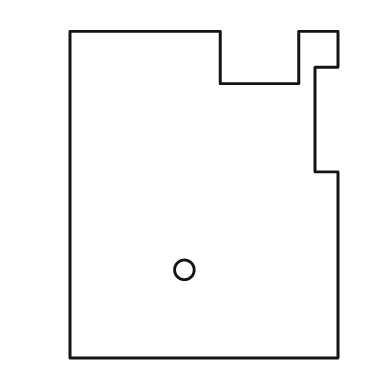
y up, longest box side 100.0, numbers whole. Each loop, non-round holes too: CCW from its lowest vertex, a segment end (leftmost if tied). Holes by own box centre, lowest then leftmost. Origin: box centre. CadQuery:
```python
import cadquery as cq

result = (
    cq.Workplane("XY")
    .moveTo(-41.0, -50.0)
    .lineTo(41.0, -50.0)
    .lineTo(41.0, 7.0)
    .lineTo(34.0, 7.0)
    .lineTo(34.0, 39.0)
    .lineTo(41.0, 39.0)
    .lineTo(41.0, 50.0)
    .lineTo(29.0, 50.0)
    .lineTo(29.0, 34.0)
    .lineTo(5.0, 34.0)
    .lineTo(5.0, 50.0)
    .lineTo(-41.0, 50.0)
    .close()
    .moveTo(-6.0, -23.0)
    .circle(3.0)
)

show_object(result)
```